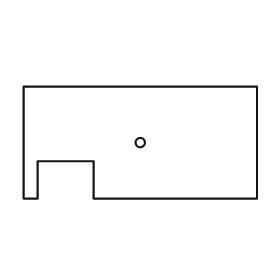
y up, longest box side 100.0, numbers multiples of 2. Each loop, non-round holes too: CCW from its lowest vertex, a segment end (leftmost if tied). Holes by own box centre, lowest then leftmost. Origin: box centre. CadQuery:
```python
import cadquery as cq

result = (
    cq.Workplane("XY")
    .moveTo(-50.0, -24.0)
    .lineTo(-44.0, -24.0)
    .lineTo(-44.0, -8.0)
    .lineTo(-20.0, -8.0)
    .lineTo(-20.0, -24.0)
    .lineTo(50.0, -24.0)
    .lineTo(50.0, 24.0)
    .lineTo(-50.0, 24.0)
    .close()
    .moveTo(0.0, 0.0)
    .circle(2.0)
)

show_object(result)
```